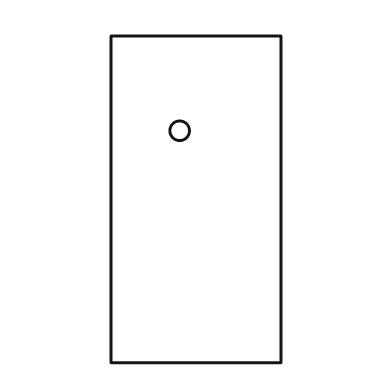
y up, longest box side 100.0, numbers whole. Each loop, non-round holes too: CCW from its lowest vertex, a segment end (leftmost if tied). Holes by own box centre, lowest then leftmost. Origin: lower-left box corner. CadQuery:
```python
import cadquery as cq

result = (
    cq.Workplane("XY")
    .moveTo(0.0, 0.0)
    .lineTo(52.0, 0.0)
    .lineTo(52.0, 100.0)
    .lineTo(0.0, 100.0)
    .close()
    .moveTo(21.0, 71.0)
    .circle(3.0)
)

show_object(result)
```